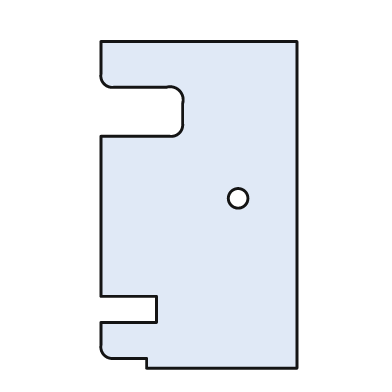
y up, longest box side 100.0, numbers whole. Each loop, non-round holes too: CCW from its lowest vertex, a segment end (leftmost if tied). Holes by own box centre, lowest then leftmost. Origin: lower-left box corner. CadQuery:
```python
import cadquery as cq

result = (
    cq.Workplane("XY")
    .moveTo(14.0, 0.0)
    .lineTo(60.0, 0.0)
    .lineTo(60.0, 100.0)
    .lineTo(0.0, 100.0)
    .lineTo(0.0, 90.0)
    .threePointArc((1.0, 87.0), (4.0, 86.0))
    .lineTo(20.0, 86.0)
    .threePointArc((24.0, 85.0), (25.0, 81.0))
    .lineTo(25.0, 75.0)
    .threePointArc((24.0, 72.0), (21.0, 71.0))
    .lineTo(0.0, 71.0)
    .lineTo(0.0, 22.0)
    .lineTo(17.0, 22.0)
    .lineTo(17.0, 14.0)
    .lineTo(0.0, 14.0)
    .lineTo(0.0, 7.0)
    .threePointArc((1.0, 4.0), (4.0, 3.0))
    .lineTo(14.0, 3.0)
    .close()
    .moveTo(42.0, 52.0)
    .circle(3.0)
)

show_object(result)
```